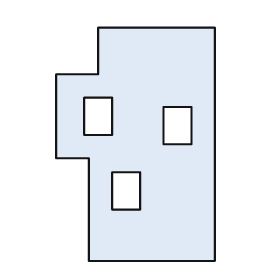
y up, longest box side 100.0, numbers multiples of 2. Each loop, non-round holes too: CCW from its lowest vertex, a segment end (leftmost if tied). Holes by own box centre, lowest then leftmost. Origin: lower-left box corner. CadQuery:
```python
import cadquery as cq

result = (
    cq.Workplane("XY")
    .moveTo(14.0, 0.0)
    .lineTo(68.0, 0.0)
    .lineTo(68.0, 100.0)
    .lineTo(18.0, 100.0)
    .lineTo(18.0, 80.0)
    .lineTo(0.0, 80.0)
    .lineTo(0.0, 44.0)
    .lineTo(14.0, 44.0)
    .close()
    .moveTo(24.0, 22.0)
    .lineTo(36.0, 22.0)
    .lineTo(36.0, 38.0)
    .lineTo(24.0, 38.0)
    .close()
    .moveTo(46.0, 50.0)
    .lineTo(58.0, 50.0)
    .lineTo(58.0, 66.0)
    .lineTo(46.0, 66.0)
    .close()
    .moveTo(12.0, 54.0)
    .lineTo(24.0, 54.0)
    .lineTo(24.0, 70.0)
    .lineTo(12.0, 70.0)
    .close()
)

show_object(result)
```